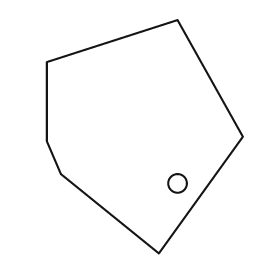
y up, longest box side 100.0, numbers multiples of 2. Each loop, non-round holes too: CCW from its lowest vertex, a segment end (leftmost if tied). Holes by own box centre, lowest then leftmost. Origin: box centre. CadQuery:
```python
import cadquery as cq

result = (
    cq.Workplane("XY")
    .moveTo(6.0, -50.0)
    .lineTo(42.0, 0.0)
    .lineTo(14.0, 50.0)
    .lineTo(-42.0, 32.0)
    .lineTo(-42.0, -2.0)
    .lineTo(-36.0, -16.0)
    .close()
    .moveTo(14.0, -20.0)
    .circle(4.0)
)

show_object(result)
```